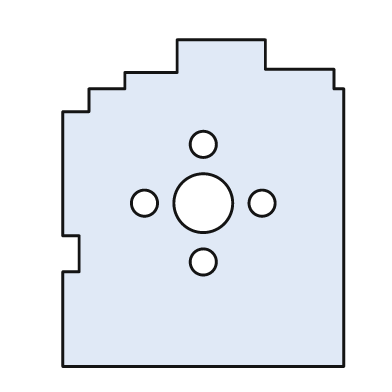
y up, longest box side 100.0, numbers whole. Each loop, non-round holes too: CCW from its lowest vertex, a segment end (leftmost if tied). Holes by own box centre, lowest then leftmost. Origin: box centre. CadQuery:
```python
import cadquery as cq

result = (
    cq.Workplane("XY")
    .moveTo(-43.0, -50.0)
    .lineTo(43.0, -50.0)
    .lineTo(43.0, 35.0)
    .lineTo(40.0, 35.0)
    .lineTo(40.0, 41.0)
    .lineTo(19.0, 41.0)
    .lineTo(19.0, 50.0)
    .lineTo(-8.0, 50.0)
    .lineTo(-8.0, 40.0)
    .lineTo(-24.0, 40.0)
    .lineTo(-24.0, 35.0)
    .lineTo(-35.0, 35.0)
    .lineTo(-35.0, 28.0)
    .lineTo(-43.0, 28.0)
    .lineTo(-43.0, -10.0)
    .lineTo(-38.0, -10.0)
    .lineTo(-38.0, -21.0)
    .lineTo(-43.0, -21.0)
    .close()
    .moveTo(0.0, -18.0)
    .circle(4.0)
    .moveTo(-18.0, 0.0)
    .circle(4.0)
    .moveTo(0.0, 0.0)
    .circle(9.0)
    .moveTo(18.0, 0.0)
    .circle(4.0)
    .moveTo(0.0, 18.0)
    .circle(4.0)
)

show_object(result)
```